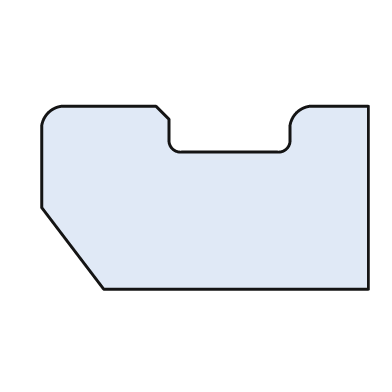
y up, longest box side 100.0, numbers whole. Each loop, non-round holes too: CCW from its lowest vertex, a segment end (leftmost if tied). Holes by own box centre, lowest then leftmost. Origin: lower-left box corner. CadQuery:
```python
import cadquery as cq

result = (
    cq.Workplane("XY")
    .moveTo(19.0, 0.0)
    .lineTo(100.0, 0.0)
    .lineTo(100.0, 56.0)
    .lineTo(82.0, 56.0)
    .threePointArc((78.0, 54.0), (76.0, 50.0))
    .lineTo(76.0, 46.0)
    .threePointArc((75.0, 43.0), (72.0, 42.0))
    .lineTo(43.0, 42.0)
    .threePointArc((40.0, 43.0), (39.0, 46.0))
    .lineTo(39.0, 52.0)
    .lineTo(35.0, 56.0)
    .lineTo(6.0, 56.0)
    .threePointArc((2.0, 54.0), (0.0, 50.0))
    .lineTo(0.0, 25.0)
    .close()
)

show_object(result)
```